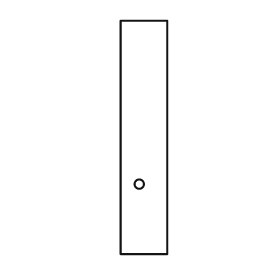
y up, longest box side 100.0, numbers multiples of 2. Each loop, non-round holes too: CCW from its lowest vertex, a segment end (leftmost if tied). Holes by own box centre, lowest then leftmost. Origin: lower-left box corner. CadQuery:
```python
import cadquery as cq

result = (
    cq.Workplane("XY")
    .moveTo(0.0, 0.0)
    .lineTo(20.0, 0.0)
    .lineTo(20.0, 100.0)
    .lineTo(0.0, 100.0)
    .close()
    .moveTo(8.0, 30.0)
    .circle(2.0)
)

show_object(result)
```